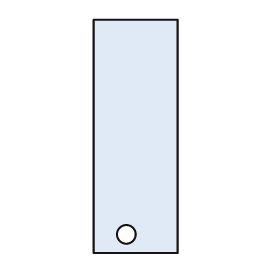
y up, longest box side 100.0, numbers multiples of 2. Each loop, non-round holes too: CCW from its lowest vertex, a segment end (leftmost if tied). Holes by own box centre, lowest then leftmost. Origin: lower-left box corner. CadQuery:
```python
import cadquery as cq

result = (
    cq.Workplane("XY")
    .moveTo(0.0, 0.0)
    .lineTo(36.0, 0.0)
    .lineTo(36.0, 100.0)
    .lineTo(0.0, 100.0)
    .close()
    .moveTo(14.0, 8.0)
    .circle(4.0)
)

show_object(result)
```